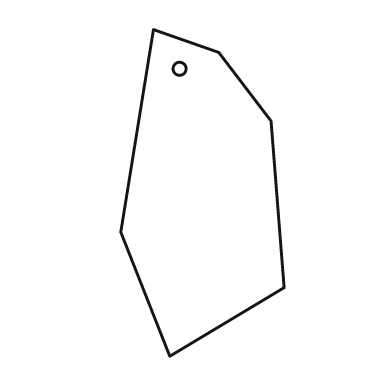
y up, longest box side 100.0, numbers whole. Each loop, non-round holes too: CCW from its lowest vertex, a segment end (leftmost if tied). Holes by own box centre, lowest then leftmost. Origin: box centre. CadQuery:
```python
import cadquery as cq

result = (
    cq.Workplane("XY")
    .moveTo(-10.0, -50.0)
    .lineTo(25.0, -29.0)
    .lineTo(21.0, 22.0)
    .lineTo(5.0, 43.0)
    .lineTo(-15.0, 50.0)
    .lineTo(-25.0, -12.0)
    .close()
    .moveTo(-7.0, 38.0)
    .circle(2.0)
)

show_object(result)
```